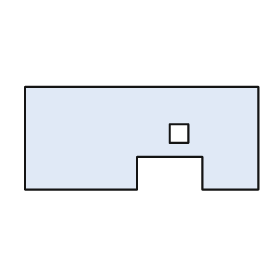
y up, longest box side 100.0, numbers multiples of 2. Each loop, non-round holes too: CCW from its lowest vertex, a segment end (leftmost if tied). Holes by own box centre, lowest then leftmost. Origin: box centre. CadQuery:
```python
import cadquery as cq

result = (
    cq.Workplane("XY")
    .moveTo(-50.0, -22.0)
    .lineTo(-2.0, -22.0)
    .lineTo(-2.0, -8.0)
    .lineTo(26.0, -8.0)
    .lineTo(26.0, -22.0)
    .lineTo(50.0, -22.0)
    .lineTo(50.0, 22.0)
    .lineTo(-50.0, 22.0)
    .close()
    .moveTo(12.0, -2.0)
    .lineTo(20.0, -2.0)
    .lineTo(20.0, 6.0)
    .lineTo(12.0, 6.0)
    .close()
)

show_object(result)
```